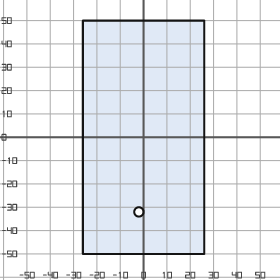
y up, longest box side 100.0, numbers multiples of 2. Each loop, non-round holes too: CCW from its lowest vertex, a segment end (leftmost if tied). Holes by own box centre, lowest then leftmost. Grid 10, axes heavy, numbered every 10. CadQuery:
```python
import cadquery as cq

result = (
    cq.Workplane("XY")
    .moveTo(-26.0, -50.0)
    .lineTo(26.0, -50.0)
    .lineTo(26.0, 50.0)
    .lineTo(-26.0, 50.0)
    .close()
    .moveTo(-2.0, -32.0)
    .circle(2.0)
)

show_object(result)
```